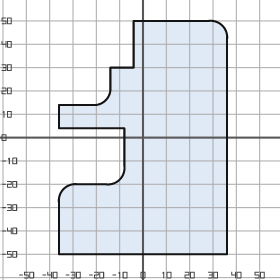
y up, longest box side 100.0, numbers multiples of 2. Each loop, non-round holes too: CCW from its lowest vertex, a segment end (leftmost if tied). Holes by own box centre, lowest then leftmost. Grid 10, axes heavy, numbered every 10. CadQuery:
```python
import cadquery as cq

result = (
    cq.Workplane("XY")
    .moveTo(-36.0, -50.0)
    .lineTo(36.0, -50.0)
    .lineTo(36.0, 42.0)
    .threePointArc((34.0, 48.0), (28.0, 50.0))
    .lineTo(-4.0, 50.0)
    .lineTo(-4.0, 30.0)
    .lineTo(-14.0, 30.0)
    .lineTo(-14.0, 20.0)
    .threePointArc((-16.0, 16.0), (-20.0, 14.0))
    .lineTo(-36.0, 14.0)
    .lineTo(-36.0, 4.0)
    .lineTo(-8.0, 4.0)
    .lineTo(-8.0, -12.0)
    .threePointArc((-10.0, -18.0), (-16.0, -20.0))
    .lineTo(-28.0, -20.0)
    .threePointArc((-34.0, -22.0), (-36.0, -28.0))
    .close()
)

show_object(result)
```